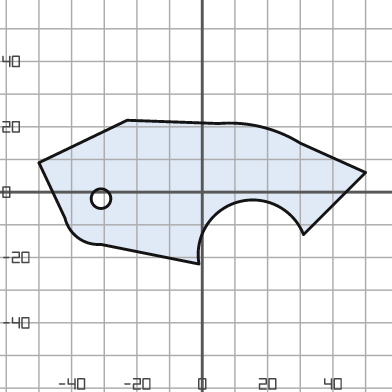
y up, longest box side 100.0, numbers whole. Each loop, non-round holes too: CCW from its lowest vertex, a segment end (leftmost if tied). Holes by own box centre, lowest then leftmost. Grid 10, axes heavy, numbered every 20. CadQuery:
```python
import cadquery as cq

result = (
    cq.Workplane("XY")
    .moveTo(-1.0, -22.0)
    .threePointArc((11.0, -3.0), (31.0, -13.0))
    .lineTo(50.0, 6.0)
    .lineTo(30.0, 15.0)
    .threePointArc((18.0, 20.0), (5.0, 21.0))
    .lineTo(-23.0, 22.0)
    .lineTo(-50.0, 9.0)
    .lineTo(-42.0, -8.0)
    .threePointArc((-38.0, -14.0), (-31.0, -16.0))
    .close()
    .moveTo(-31.0, -2.0)
    .circle(3.0)
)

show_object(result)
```